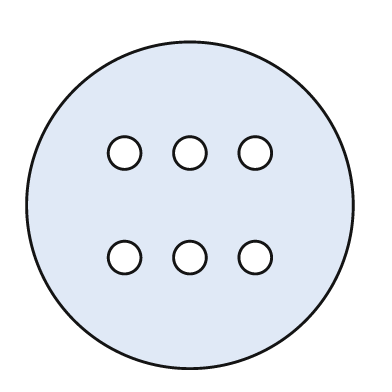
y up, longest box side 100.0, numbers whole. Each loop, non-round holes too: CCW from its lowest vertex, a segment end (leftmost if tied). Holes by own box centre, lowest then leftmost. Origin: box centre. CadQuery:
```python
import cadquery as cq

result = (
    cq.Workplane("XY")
    .moveTo(0.0, 0.0)
    .circle(50.0)
    .moveTo(-20.0, -16.0)
    .circle(5.0)
    .moveTo(0.0, -16.0)
    .circle(5.0)
    .moveTo(20.0, -16.0)
    .circle(5.0)
    .moveTo(-20.0, 16.0)
    .circle(5.0)
    .moveTo(0.0, 16.0)
    .circle(5.0)
    .moveTo(20.0, 16.0)
    .circle(5.0)
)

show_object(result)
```